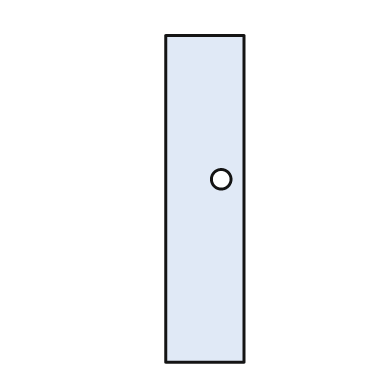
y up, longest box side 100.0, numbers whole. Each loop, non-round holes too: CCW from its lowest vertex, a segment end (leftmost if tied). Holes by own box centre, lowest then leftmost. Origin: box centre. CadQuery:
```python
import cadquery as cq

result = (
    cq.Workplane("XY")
    .moveTo(-12.0, -50.0)
    .lineTo(12.0, -50.0)
    .lineTo(12.0, 50.0)
    .lineTo(-12.0, 50.0)
    .close()
    .moveTo(5.0, 6.0)
    .circle(3.0)
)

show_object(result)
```